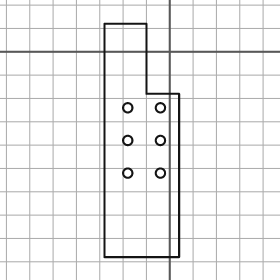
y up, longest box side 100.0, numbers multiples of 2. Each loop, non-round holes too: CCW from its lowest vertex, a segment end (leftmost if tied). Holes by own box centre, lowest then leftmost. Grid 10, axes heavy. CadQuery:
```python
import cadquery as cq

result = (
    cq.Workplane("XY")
    .moveTo(-28.0, -88.0)
    .lineTo(4.0, -88.0)
    .lineTo(4.0, -18.0)
    .lineTo(-10.0, -18.0)
    .lineTo(-10.0, 12.0)
    .lineTo(-28.0, 12.0)
    .close()
    .moveTo(-18.0, -52.0)
    .circle(2.0)
    .moveTo(-4.0, -52.0)
    .circle(2.0)
    .moveTo(-18.0, -38.0)
    .circle(2.0)
    .moveTo(-4.0, -38.0)
    .circle(2.0)
    .moveTo(-18.0, -24.0)
    .circle(2.0)
    .moveTo(-4.0, -24.0)
    .circle(2.0)
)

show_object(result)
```